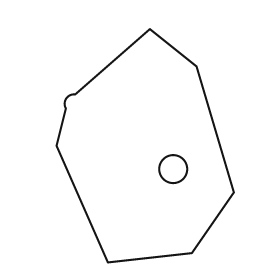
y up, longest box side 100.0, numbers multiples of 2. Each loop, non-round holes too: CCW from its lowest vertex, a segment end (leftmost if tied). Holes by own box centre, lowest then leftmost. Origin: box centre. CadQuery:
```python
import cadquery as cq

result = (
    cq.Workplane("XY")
    .moveTo(-16.0, -50.0)
    .lineTo(20.0, -46.0)
    .lineTo(38.0, -20.0)
    .lineTo(22.0, 34.0)
    .lineTo(2.0, 50.0)
    .lineTo(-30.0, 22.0)
    .threePointArc((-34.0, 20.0), (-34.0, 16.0))
    .lineTo(-38.0, 0.0)
    .close()
    .moveTo(12.0, -10.0)
    .circle(6.0)
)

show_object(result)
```